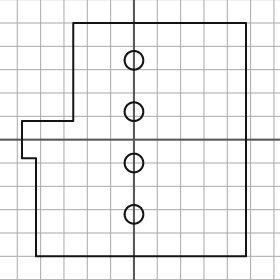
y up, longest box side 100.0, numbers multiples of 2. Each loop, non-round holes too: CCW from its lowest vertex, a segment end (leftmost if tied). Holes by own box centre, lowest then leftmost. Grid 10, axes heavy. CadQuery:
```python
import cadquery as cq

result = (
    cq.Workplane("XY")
    .moveTo(-42.0, -50.0)
    .lineTo(48.0, -50.0)
    .lineTo(48.0, 50.0)
    .lineTo(-26.0, 50.0)
    .lineTo(-26.0, 8.0)
    .lineTo(-48.0, 8.0)
    .lineTo(-48.0, -8.0)
    .lineTo(-42.0, -8.0)
    .close()
    .moveTo(0.0, -32.0)
    .circle(4.0)
    .moveTo(0.0, -10.0)
    .circle(4.0)
    .moveTo(0.0, 12.0)
    .circle(4.0)
    .moveTo(0.0, 34.0)
    .circle(4.0)
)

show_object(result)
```